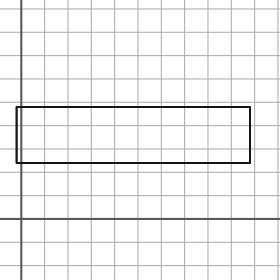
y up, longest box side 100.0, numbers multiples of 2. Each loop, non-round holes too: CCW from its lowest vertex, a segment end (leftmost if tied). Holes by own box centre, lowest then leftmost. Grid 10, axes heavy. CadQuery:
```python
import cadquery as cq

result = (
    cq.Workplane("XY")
    .moveTo(-2.0, 24.0)
    .lineTo(98.0, 24.0)
    .lineTo(98.0, 48.0)
    .lineTo(-2.0, 48.0)
    .close()
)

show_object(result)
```